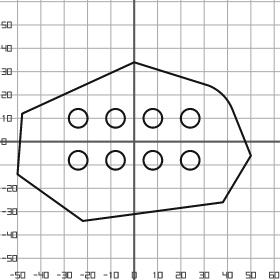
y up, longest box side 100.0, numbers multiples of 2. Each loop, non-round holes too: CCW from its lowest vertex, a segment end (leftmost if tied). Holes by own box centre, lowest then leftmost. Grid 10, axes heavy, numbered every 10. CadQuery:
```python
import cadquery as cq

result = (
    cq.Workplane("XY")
    .moveTo(-22.0, -34.0)
    .lineTo(38.0, -26.0)
    .lineTo(50.0, -6.0)
    .lineTo(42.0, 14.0)
    .threePointArc((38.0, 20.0), (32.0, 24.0))
    .lineTo(0.0, 34.0)
    .lineTo(-48.0, 12.0)
    .lineTo(-50.0, -14.0)
    .close()
    .moveTo(-24.0, -8.0)
    .circle(4.0)
    .moveTo(-8.0, -8.0)
    .circle(4.0)
    .moveTo(8.0, -8.0)
    .circle(4.0)
    .moveTo(24.0, -8.0)
    .circle(4.0)
    .moveTo(-24.0, 10.0)
    .circle(4.0)
    .moveTo(-8.0, 10.0)
    .circle(4.0)
    .moveTo(8.0, 10.0)
    .circle(4.0)
    .moveTo(24.0, 10.0)
    .circle(4.0)
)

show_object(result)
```